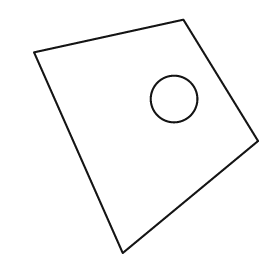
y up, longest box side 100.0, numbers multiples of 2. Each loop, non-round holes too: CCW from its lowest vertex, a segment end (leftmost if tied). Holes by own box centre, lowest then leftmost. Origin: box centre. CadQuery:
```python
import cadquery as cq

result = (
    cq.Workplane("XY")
    .moveTo(-10.0, -50.0)
    .lineTo(48.0, -2.0)
    .lineTo(16.0, 50.0)
    .lineTo(-48.0, 36.0)
    .close()
    .moveTo(12.0, 16.0)
    .circle(10.0)
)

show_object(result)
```